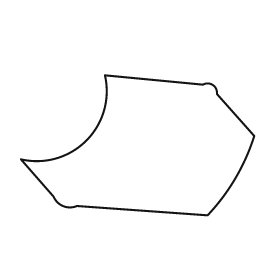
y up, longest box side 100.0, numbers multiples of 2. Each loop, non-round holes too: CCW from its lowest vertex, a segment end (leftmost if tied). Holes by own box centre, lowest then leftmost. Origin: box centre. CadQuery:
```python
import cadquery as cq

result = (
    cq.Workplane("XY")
    .moveTo(30.0, -30.0)
    .threePointArc((42.0, -14.0), (50.0, 4.0))
    .lineTo(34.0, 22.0)
    .threePointArc((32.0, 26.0), (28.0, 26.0))
    .lineTo(-14.0, 30.0)
    .threePointArc((-22.0, 2.0), (-50.0, -6.0))
    .lineTo(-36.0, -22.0)
    .threePointArc((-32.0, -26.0), (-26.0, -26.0))
    .close()
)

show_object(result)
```